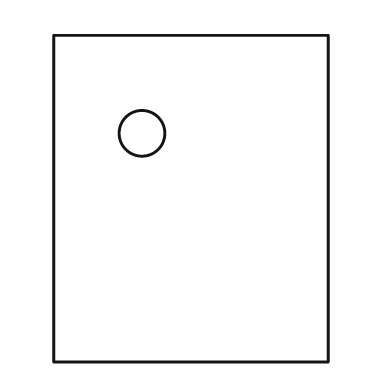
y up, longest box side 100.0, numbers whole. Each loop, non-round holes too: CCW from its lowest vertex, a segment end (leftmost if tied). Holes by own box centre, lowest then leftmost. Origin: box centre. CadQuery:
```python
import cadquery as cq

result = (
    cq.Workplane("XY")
    .moveTo(-42.0, -50.0)
    .lineTo(42.0, -50.0)
    .lineTo(42.0, 50.0)
    .lineTo(-42.0, 50.0)
    .close()
    .moveTo(-15.0, 20.0)
    .circle(7.0)
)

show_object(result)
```